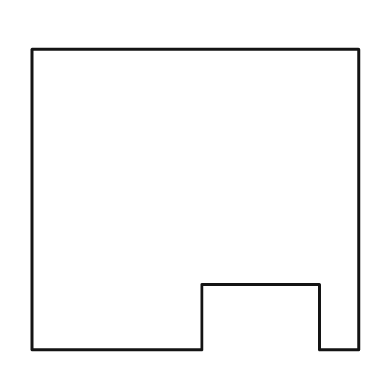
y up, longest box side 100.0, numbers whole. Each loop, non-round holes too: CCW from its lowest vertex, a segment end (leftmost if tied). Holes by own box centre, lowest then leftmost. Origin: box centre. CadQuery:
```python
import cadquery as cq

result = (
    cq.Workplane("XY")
    .moveTo(-50.0, -46.0)
    .lineTo(2.0, -46.0)
    .lineTo(2.0, -26.0)
    .lineTo(38.0, -26.0)
    .lineTo(38.0, -46.0)
    .lineTo(50.0, -46.0)
    .lineTo(50.0, 46.0)
    .lineTo(-50.0, 46.0)
    .close()
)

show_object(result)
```